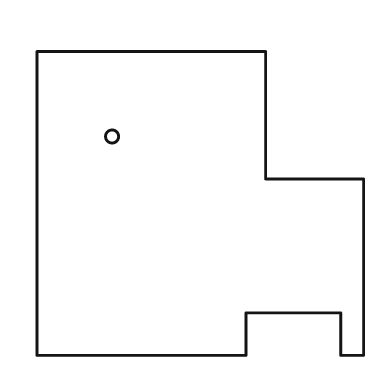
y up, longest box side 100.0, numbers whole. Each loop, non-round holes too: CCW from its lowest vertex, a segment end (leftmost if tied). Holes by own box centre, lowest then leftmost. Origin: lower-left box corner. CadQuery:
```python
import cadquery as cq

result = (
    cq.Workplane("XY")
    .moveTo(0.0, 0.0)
    .lineTo(64.0, 0.0)
    .lineTo(64.0, 13.0)
    .lineTo(93.0, 13.0)
    .lineTo(93.0, 0.0)
    .lineTo(100.0, 0.0)
    .lineTo(100.0, 54.0)
    .lineTo(70.0, 54.0)
    .lineTo(70.0, 93.0)
    .lineTo(0.0, 93.0)
    .close()
    .moveTo(23.0, 67.0)
    .circle(2.0)
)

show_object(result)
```